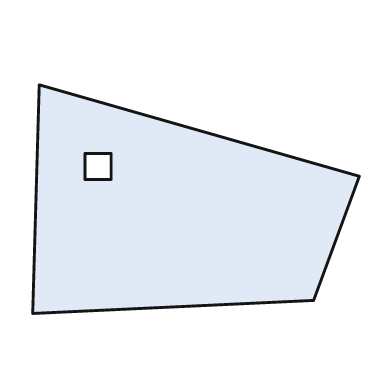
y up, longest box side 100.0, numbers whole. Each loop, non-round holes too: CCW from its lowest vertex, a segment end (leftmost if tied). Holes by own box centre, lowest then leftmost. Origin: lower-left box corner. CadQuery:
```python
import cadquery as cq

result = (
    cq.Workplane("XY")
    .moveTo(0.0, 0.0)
    .lineTo(86.0, 4.0)
    .lineTo(100.0, 42.0)
    .lineTo(2.0, 70.0)
    .close()
    .moveTo(16.0, 41.0)
    .lineTo(24.0, 41.0)
    .lineTo(24.0, 49.0)
    .lineTo(16.0, 49.0)
    .close()
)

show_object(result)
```